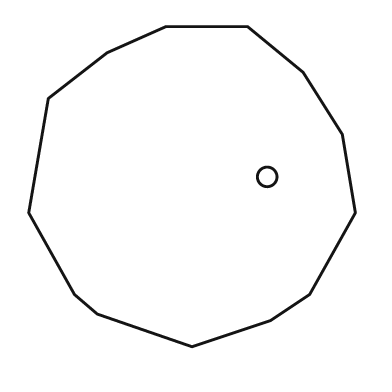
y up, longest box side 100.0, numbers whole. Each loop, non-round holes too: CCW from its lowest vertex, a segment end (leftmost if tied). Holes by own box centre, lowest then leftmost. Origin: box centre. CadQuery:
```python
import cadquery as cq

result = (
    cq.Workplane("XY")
    .moveTo(0.0, -49.0)
    .lineTo(24.0, -41.0)
    .lineTo(36.0, -33.0)
    .lineTo(50.0, -8.0)
    .lineTo(46.0, 16.0)
    .lineTo(34.0, 35.0)
    .lineTo(17.0, 49.0)
    .lineTo(-8.0, 49.0)
    .lineTo(-26.0, 41.0)
    .lineTo(-44.0, 27.0)
    .lineTo(-50.0, -8.0)
    .lineTo(-36.0, -33.0)
    .lineTo(-29.0, -39.0)
    .close()
    .moveTo(23.0, 3.0)
    .circle(3.0)
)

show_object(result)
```